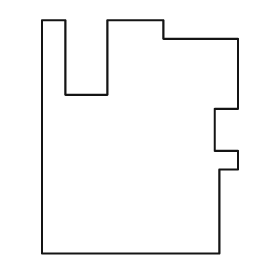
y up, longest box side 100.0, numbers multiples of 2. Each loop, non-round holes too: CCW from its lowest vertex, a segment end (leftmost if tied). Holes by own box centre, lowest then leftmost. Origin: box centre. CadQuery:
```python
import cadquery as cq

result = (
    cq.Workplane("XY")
    .moveTo(-42.0, -50.0)
    .lineTo(34.0, -50.0)
    .lineTo(34.0, -14.0)
    .lineTo(42.0, -14.0)
    .lineTo(42.0, -6.0)
    .lineTo(32.0, -6.0)
    .lineTo(32.0, 12.0)
    .lineTo(42.0, 12.0)
    .lineTo(42.0, 42.0)
    .lineTo(10.0, 42.0)
    .lineTo(10.0, 50.0)
    .lineTo(-14.0, 50.0)
    .lineTo(-14.0, 18.0)
    .lineTo(-32.0, 18.0)
    .lineTo(-32.0, 50.0)
    .lineTo(-42.0, 50.0)
    .close()
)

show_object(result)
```